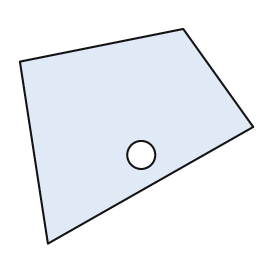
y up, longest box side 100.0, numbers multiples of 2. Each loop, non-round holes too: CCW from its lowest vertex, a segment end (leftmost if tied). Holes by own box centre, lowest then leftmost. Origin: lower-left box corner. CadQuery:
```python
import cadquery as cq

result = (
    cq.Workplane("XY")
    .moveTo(12.0, 0.0)
    .lineTo(100.0, 50.0)
    .lineTo(70.0, 92.0)
    .lineTo(0.0, 78.0)
    .close()
    .moveTo(52.0, 38.0)
    .circle(6.0)
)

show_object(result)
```